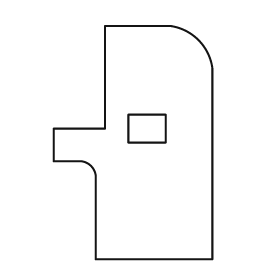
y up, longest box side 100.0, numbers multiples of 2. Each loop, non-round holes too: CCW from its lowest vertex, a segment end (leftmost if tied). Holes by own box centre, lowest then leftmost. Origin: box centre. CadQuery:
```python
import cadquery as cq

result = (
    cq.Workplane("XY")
    .moveTo(-16.0, -50.0)
    .lineTo(34.0, -50.0)
    .lineTo(34.0, 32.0)
    .threePointArc((28.0, 44.0), (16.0, 50.0))
    .lineTo(-12.0, 50.0)
    .lineTo(-12.0, 6.0)
    .lineTo(-34.0, 6.0)
    .lineTo(-34.0, -8.0)
    .lineTo(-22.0, -8.0)
    .threePointArc((-18.0, -10.0), (-16.0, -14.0))
    .close()
    .moveTo(-2.0, 0.0)
    .lineTo(14.0, 0.0)
    .lineTo(14.0, 12.0)
    .lineTo(-2.0, 12.0)
    .close()
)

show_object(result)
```